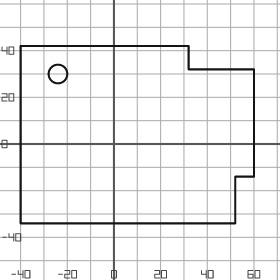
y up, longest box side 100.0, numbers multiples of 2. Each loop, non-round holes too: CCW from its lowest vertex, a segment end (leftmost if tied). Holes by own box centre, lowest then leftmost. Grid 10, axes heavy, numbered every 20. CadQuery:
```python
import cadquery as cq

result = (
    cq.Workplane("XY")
    .moveTo(-40.0, -34.0)
    .lineTo(52.0, -34.0)
    .lineTo(52.0, -14.0)
    .lineTo(60.0, -14.0)
    .lineTo(60.0, 32.0)
    .lineTo(32.0, 32.0)
    .lineTo(32.0, 42.0)
    .lineTo(-40.0, 42.0)
    .close()
    .moveTo(-24.0, 30.0)
    .circle(4.0)
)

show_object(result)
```